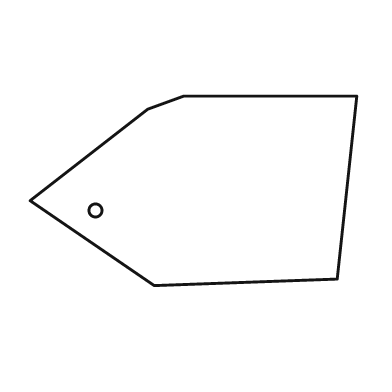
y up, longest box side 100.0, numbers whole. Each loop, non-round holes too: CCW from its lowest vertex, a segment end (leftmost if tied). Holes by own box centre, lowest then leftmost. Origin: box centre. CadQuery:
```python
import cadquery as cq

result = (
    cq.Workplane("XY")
    .moveTo(-12.0, -29.0)
    .lineTo(44.0, -27.0)
    .lineTo(50.0, 29.0)
    .lineTo(-3.0, 29.0)
    .lineTo(-14.0, 25.0)
    .lineTo(-50.0, -3.0)
    .close()
    .moveTo(-30.0, -6.0)
    .circle(2.0)
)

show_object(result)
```